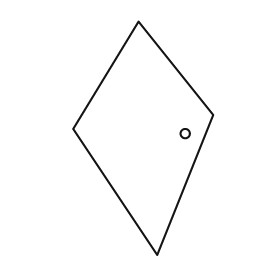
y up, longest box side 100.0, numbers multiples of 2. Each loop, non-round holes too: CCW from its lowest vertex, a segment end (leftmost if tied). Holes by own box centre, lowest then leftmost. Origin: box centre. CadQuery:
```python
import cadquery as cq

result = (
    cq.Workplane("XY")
    .moveTo(6.0, -50.0)
    .lineTo(30.0, 10.0)
    .lineTo(-2.0, 50.0)
    .lineTo(-30.0, 4.0)
    .close()
    .moveTo(18.0, 2.0)
    .circle(2.0)
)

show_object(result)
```